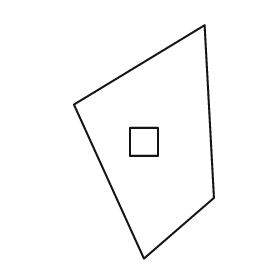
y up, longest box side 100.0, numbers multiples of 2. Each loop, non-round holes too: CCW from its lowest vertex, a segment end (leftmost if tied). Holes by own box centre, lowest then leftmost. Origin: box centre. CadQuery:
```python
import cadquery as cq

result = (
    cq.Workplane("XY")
    .moveTo(0.0, -50.0)
    .lineTo(30.0, -24.0)
    .lineTo(26.0, 50.0)
    .lineTo(-30.0, 16.0)
    .close()
    .moveTo(-6.0, -6.0)
    .lineTo(6.0, -6.0)
    .lineTo(6.0, 6.0)
    .lineTo(-6.0, 6.0)
    .close()
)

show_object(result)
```